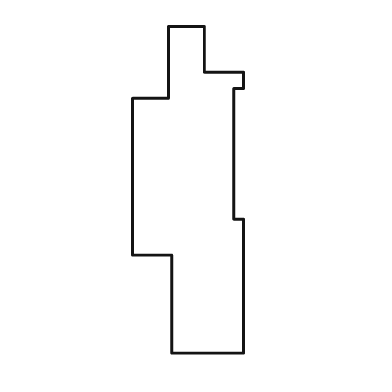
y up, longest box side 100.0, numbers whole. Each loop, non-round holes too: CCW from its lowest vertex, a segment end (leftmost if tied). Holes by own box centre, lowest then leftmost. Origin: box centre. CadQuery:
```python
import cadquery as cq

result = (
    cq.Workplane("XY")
    .moveTo(-5.0, -50.0)
    .lineTo(17.0, -50.0)
    .lineTo(17.0, -9.0)
    .lineTo(14.0, -9.0)
    .lineTo(14.0, 31.0)
    .lineTo(17.0, 31.0)
    .lineTo(17.0, 36.0)
    .lineTo(5.0, 36.0)
    .lineTo(5.0, 50.0)
    .lineTo(-6.0, 50.0)
    .lineTo(-6.0, 28.0)
    .lineTo(-17.0, 28.0)
    .lineTo(-17.0, -20.0)
    .lineTo(-5.0, -20.0)
    .close()
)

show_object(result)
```